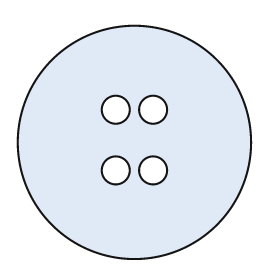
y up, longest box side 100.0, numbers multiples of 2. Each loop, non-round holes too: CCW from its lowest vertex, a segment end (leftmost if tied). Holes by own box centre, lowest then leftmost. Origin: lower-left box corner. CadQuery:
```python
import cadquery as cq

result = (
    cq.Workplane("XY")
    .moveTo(50.0, 50.0)
    .circle(50.0)
    .moveTo(42.0, 38.0)
    .circle(6.0)
    .moveTo(58.0, 38.0)
    .circle(6.0)
    .moveTo(42.0, 64.0)
    .circle(6.0)
    .moveTo(58.0, 64.0)
    .circle(6.0)
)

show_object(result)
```